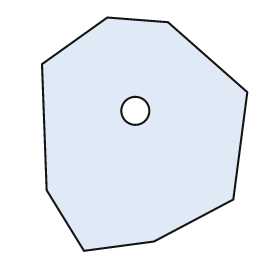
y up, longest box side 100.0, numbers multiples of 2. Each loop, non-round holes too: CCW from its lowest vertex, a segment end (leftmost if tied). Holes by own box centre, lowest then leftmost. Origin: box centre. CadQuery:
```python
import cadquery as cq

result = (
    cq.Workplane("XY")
    .moveTo(-26.0, -50.0)
    .lineTo(4.0, -46.0)
    .lineTo(38.0, -28.0)
    .lineTo(44.0, 18.0)
    .lineTo(10.0, 48.0)
    .lineTo(-16.0, 50.0)
    .lineTo(-44.0, 30.0)
    .lineTo(-42.0, -24.0)
    .close()
    .moveTo(-4.0, 10.0)
    .circle(6.0)
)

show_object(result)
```